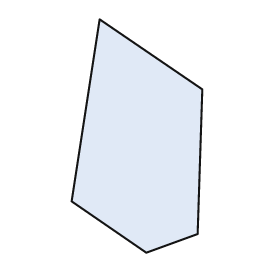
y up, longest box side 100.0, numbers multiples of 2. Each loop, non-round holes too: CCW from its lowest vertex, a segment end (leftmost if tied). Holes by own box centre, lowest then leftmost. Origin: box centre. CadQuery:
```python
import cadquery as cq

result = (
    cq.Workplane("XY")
    .moveTo(4.0, -50.0)
    .lineTo(26.0, -42.0)
    .lineTo(28.0, 20.0)
    .lineTo(-16.0, 50.0)
    .lineTo(-28.0, -28.0)
    .close()
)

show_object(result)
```